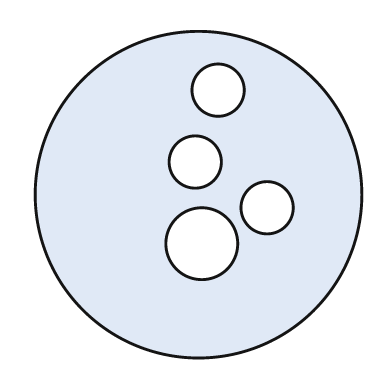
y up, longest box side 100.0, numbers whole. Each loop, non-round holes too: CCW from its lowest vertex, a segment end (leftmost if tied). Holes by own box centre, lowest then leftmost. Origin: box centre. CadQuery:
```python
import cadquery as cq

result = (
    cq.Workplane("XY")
    .moveTo(0.0, 0.0)
    .circle(50.0)
    .moveTo(1.0, -15.0)
    .circle(11.0)
    .moveTo(21.0, -4.0)
    .circle(8.0)
    .moveTo(-1.0, 10.0)
    .circle(8.0)
    .moveTo(6.0, 32.0)
    .circle(8.0)
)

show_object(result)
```